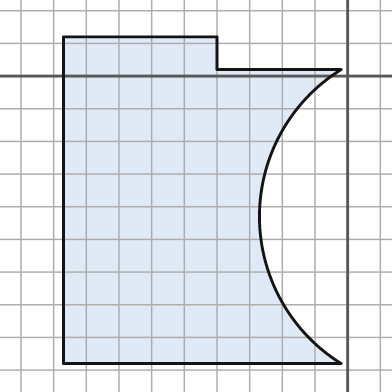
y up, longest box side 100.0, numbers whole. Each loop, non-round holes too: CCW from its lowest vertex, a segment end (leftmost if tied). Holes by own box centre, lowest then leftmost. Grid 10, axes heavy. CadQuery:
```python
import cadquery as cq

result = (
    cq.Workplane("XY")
    .moveTo(-87.0, -88.0)
    .lineTo(-2.0, -88.0)
    .threePointArc((-27.0, -43.0), (-2.0, 2.0))
    .lineTo(-40.0, 2.0)
    .lineTo(-40.0, 12.0)
    .lineTo(-87.0, 12.0)
    .close()
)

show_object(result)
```